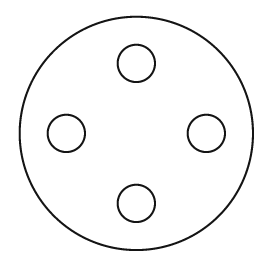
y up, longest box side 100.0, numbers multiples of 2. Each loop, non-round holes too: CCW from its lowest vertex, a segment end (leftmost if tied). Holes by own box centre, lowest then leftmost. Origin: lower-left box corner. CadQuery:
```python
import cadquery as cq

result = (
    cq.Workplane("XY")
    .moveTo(50.0, 50.0)
    .circle(50.0)
    .moveTo(50.0, 20.0)
    .circle(8.0)
    .moveTo(20.0, 50.0)
    .circle(8.0)
    .moveTo(80.0, 50.0)
    .circle(8.0)
    .moveTo(50.0, 80.0)
    .circle(8.0)
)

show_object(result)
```